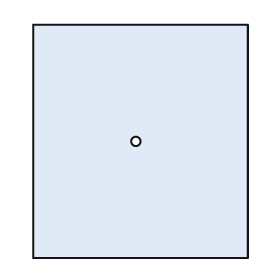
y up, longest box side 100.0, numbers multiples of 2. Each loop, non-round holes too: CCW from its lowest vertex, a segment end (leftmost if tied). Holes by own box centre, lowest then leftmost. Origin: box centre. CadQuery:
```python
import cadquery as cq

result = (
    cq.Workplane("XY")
    .moveTo(-46.0, -50.0)
    .lineTo(46.0, -50.0)
    .lineTo(46.0, 50.0)
    .lineTo(-46.0, 50.0)
    .close()
    .moveTo(-2.0, 0.0)
    .circle(2.0)
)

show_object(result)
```